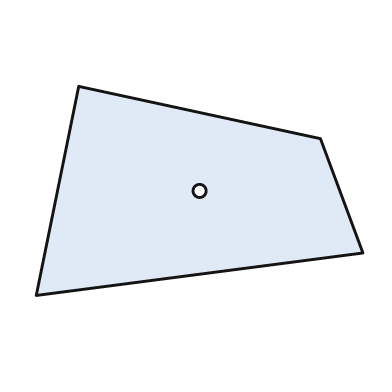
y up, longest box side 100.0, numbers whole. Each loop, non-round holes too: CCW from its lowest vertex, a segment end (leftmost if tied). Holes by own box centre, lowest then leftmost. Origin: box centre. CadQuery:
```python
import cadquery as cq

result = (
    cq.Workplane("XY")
    .moveTo(-50.0, -32.0)
    .lineTo(50.0, -19.0)
    .lineTo(37.0, 16.0)
    .lineTo(-37.0, 32.0)
    .close()
    .moveTo(0.0, 0.0)
    .circle(2.0)
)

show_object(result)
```